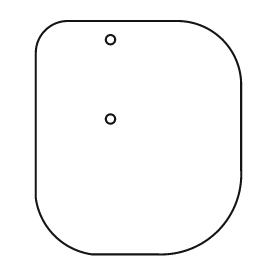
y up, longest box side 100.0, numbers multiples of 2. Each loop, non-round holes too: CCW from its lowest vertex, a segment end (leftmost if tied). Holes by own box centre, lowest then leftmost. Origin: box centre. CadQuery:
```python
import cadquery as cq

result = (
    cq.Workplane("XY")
    .moveTo(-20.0, -50.0)
    .lineTo(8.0, -50.0)
    .threePointArc((34.0, -40.0), (44.0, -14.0))
    .lineTo(44.0, 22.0)
    .threePointArc((36.0, 42.0), (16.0, 50.0))
    .lineTo(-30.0, 50.0)
    .threePointArc((-40.0, 46.0), (-44.0, 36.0))
    .lineTo(-44.0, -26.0)
    .threePointArc((-36.0, -42.0), (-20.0, -50.0))
    .close()
    .moveTo(-12.0, 8.0)
    .circle(2.0)
    .moveTo(-12.0, 42.0)
    .circle(2.0)
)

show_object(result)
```